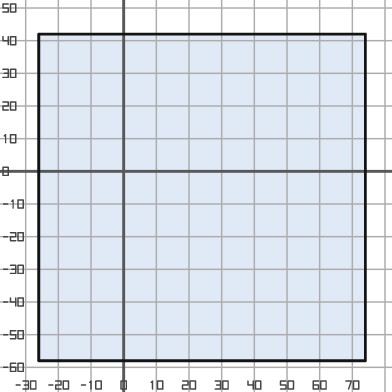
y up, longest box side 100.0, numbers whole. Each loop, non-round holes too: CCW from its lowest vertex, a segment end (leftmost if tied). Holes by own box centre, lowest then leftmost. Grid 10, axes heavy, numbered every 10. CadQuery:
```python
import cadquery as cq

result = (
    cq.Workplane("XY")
    .moveTo(-26.0, -58.0)
    .lineTo(74.0, -58.0)
    .lineTo(74.0, 42.0)
    .lineTo(-26.0, 42.0)
    .close()
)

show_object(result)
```